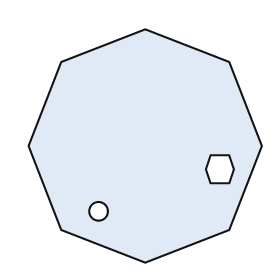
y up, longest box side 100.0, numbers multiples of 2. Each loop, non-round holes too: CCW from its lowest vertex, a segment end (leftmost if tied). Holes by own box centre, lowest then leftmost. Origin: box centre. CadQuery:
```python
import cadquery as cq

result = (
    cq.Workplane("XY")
    .moveTo(0.0, -50.0)
    .lineTo(36.0, -36.0)
    .lineTo(50.0, 0.0)
    .lineTo(36.0, 36.0)
    .lineTo(0.0, 50.0)
    .lineTo(-36.0, 36.0)
    .lineTo(-50.0, 0.0)
    .lineTo(-36.0, -36.0)
    .close()
    .moveTo(-20.0, -28.0)
    .circle(4.0)
    .moveTo(28.0, -16.0)
    .lineTo(36.0, -16.0)
    .lineTo(38.0, -10.0)
    .lineTo(36.0, -4.0)
    .lineTo(28.0, -4.0)
    .lineTo(26.0, -10.0)
    .close()
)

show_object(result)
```